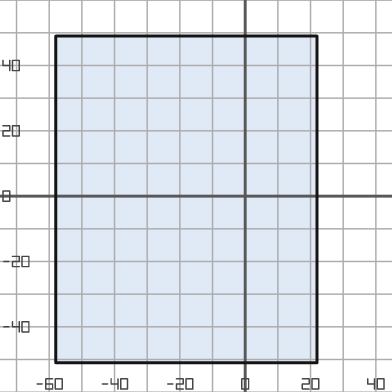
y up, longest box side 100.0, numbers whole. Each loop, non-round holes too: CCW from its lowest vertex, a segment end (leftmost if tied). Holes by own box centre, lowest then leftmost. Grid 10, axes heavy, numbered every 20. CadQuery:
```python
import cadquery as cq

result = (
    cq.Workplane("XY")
    .moveTo(-58.0, -51.0)
    .lineTo(22.0, -51.0)
    .lineTo(22.0, 49.0)
    .lineTo(-58.0, 49.0)
    .close()
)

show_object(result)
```